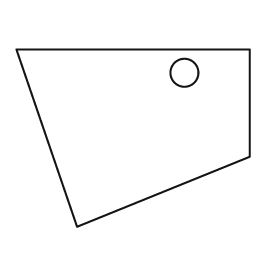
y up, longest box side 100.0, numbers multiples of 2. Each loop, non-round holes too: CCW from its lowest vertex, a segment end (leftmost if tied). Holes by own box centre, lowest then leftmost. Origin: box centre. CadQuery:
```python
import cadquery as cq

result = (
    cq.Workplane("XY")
    .moveTo(-24.0, -38.0)
    .lineTo(50.0, -8.0)
    .lineTo(50.0, 38.0)
    .lineTo(-50.0, 38.0)
    .close()
    .moveTo(22.0, 28.0)
    .circle(6.0)
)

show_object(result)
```